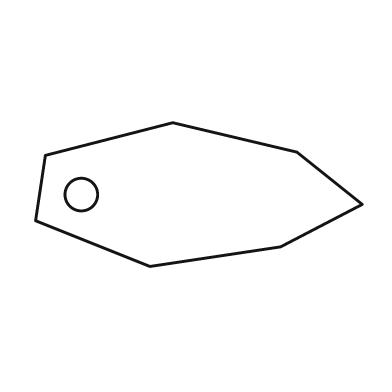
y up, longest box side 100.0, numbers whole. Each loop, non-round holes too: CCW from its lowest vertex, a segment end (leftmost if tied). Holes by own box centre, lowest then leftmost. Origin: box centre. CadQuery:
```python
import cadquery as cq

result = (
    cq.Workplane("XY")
    .moveTo(-15.0, -22.0)
    .lineTo(25.0, -16.0)
    .lineTo(50.0, -3.0)
    .lineTo(30.0, 13.0)
    .lineTo(-8.0, 22.0)
    .lineTo(-47.0, 12.0)
    .lineTo(-50.0, -8.0)
    .close()
    .moveTo(-36.0, 0.0)
    .circle(5.0)
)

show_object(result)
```